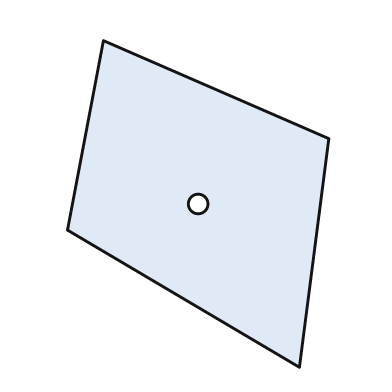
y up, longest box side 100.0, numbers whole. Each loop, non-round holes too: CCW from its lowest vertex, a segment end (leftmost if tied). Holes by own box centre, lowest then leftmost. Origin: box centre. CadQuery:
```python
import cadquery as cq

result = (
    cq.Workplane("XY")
    .moveTo(31.0, -50.0)
    .lineTo(40.0, 20.0)
    .lineTo(-29.0, 50.0)
    .lineTo(-40.0, -8.0)
    .close()
    .moveTo(0.0, 0.0)
    .circle(3.0)
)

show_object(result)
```